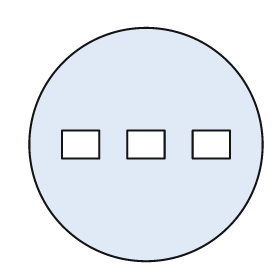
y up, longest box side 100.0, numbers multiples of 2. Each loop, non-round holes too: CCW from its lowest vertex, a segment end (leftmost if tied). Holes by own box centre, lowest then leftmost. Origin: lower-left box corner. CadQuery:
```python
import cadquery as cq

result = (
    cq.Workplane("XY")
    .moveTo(50.0, 50.0)
    .circle(50.0)
    .moveTo(14.0, 44.0)
    .lineTo(30.0, 44.0)
    .lineTo(30.0, 56.0)
    .lineTo(14.0, 56.0)
    .close()
    .moveTo(42.0, 44.0)
    .lineTo(58.0, 44.0)
    .lineTo(58.0, 56.0)
    .lineTo(42.0, 56.0)
    .close()
    .moveTo(70.0, 44.0)
    .lineTo(86.0, 44.0)
    .lineTo(86.0, 56.0)
    .lineTo(70.0, 56.0)
    .close()
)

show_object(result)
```